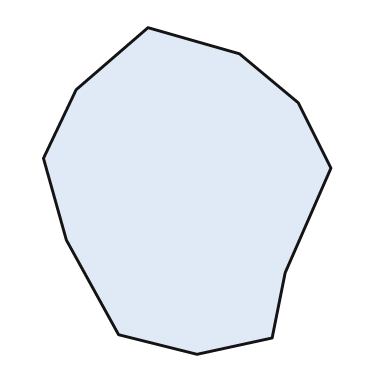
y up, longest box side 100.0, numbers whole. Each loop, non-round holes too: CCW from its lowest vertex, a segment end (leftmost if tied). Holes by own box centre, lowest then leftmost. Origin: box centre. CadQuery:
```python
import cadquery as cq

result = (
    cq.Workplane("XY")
    .moveTo(3.0, -50.0)
    .lineTo(26.0, -45.0)
    .lineTo(30.0, -25.0)
    .lineTo(44.0, 7.0)
    .lineTo(34.0, 27.0)
    .lineTo(16.0, 42.0)
    .lineTo(-12.0, 50.0)
    .lineTo(-34.0, 31.0)
    .lineTo(-44.0, 10.0)
    .lineTo(-37.0, -15.0)
    .lineTo(-21.0, -44.0)
    .close()
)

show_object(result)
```